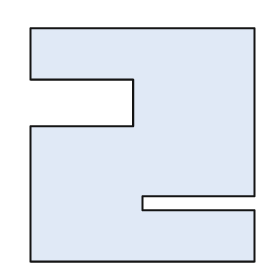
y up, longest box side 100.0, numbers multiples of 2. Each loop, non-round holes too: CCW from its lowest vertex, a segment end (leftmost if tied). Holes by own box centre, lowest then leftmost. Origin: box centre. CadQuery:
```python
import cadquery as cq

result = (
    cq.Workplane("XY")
    .moveTo(-48.0, -50.0)
    .lineTo(48.0, -50.0)
    .lineTo(48.0, -28.0)
    .lineTo(0.0, -28.0)
    .lineTo(0.0, -22.0)
    .lineTo(48.0, -22.0)
    .lineTo(48.0, 50.0)
    .lineTo(-48.0, 50.0)
    .lineTo(-48.0, 28.0)
    .lineTo(-4.0, 28.0)
    .lineTo(-4.0, 8.0)
    .lineTo(-48.0, 8.0)
    .close()
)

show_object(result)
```